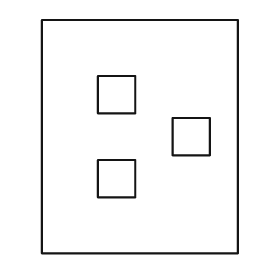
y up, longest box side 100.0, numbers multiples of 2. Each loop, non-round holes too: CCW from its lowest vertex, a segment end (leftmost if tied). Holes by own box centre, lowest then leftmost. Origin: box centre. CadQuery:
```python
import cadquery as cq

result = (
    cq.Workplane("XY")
    .moveTo(-42.0, -50.0)
    .lineTo(42.0, -50.0)
    .lineTo(42.0, 50.0)
    .lineTo(-42.0, 50.0)
    .close()
    .moveTo(-18.0, -26.0)
    .lineTo(-2.0, -26.0)
    .lineTo(-2.0, -10.0)
    .lineTo(-18.0, -10.0)
    .close()
    .moveTo(14.0, -8.0)
    .lineTo(30.0, -8.0)
    .lineTo(30.0, 8.0)
    .lineTo(14.0, 8.0)
    .close()
    .moveTo(-18.0, 10.0)
    .lineTo(-2.0, 10.0)
    .lineTo(-2.0, 26.0)
    .lineTo(-18.0, 26.0)
    .close()
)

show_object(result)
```